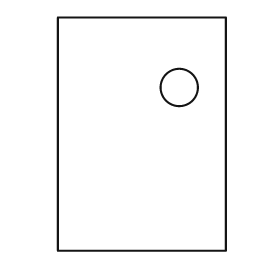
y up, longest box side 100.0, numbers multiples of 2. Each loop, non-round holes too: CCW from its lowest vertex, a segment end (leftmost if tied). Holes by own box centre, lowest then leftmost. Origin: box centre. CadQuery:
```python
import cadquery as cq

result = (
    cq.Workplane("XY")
    .moveTo(-36.0, -50.0)
    .lineTo(36.0, -50.0)
    .lineTo(36.0, 50.0)
    .lineTo(-36.0, 50.0)
    .close()
    .moveTo(16.0, 20.0)
    .circle(8.0)
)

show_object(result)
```